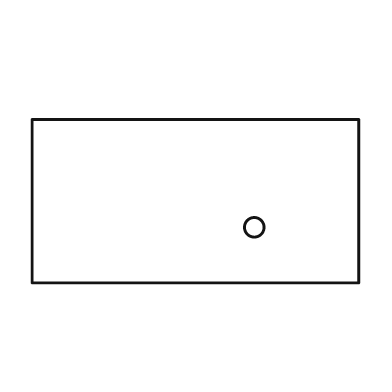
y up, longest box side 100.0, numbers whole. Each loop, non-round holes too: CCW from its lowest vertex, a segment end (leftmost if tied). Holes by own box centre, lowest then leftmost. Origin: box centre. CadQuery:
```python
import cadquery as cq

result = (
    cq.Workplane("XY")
    .moveTo(-50.0, -25.0)
    .lineTo(50.0, -25.0)
    .lineTo(50.0, 25.0)
    .lineTo(-50.0, 25.0)
    .close()
    .moveTo(18.0, -8.0)
    .circle(3.0)
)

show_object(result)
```